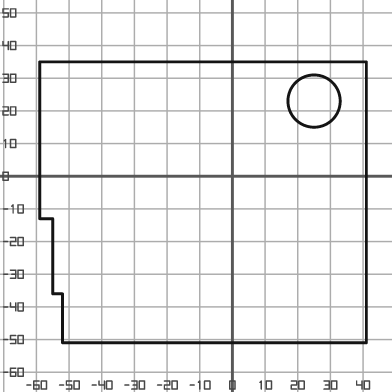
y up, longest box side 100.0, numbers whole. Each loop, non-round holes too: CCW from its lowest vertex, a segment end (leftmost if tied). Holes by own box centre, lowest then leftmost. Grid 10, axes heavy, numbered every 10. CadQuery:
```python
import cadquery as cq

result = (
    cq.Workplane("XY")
    .moveTo(-52.0, -51.0)
    .lineTo(41.0, -51.0)
    .lineTo(41.0, 35.0)
    .lineTo(-59.0, 35.0)
    .lineTo(-59.0, -13.0)
    .lineTo(-55.0, -13.0)
    .lineTo(-55.0, -36.0)
    .lineTo(-52.0, -36.0)
    .close()
    .moveTo(25.0, 23.0)
    .circle(8.0)
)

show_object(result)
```